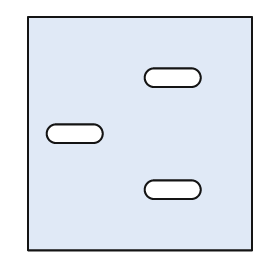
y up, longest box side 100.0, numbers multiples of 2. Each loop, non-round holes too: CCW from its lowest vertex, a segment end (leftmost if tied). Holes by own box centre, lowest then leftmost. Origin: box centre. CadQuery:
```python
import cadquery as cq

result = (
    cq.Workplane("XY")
    .moveTo(-48.0, -50.0)
    .lineTo(48.0, -50.0)
    .lineTo(48.0, 50.0)
    .lineTo(-48.0, 50.0)
    .close()
    .moveTo(6.0, -28.0)
    .lineTo(22.0, -28.0)
    .threePointArc((26.0, -24.0), (22.0, -20.0))
    .lineTo(6.0, -20.0)
    .threePointArc((2.0, -24.0), (6.0, -28.0))
    .close()
    .moveTo(-36.0, -4.0)
    .lineTo(-20.0, -4.0)
    .threePointArc((-16.0, 0.0), (-20.0, 4.0))
    .lineTo(-36.0, 4.0)
    .threePointArc((-40.0, 0.0), (-36.0, -4.0))
    .close()
    .moveTo(6.0, 20.0)
    .lineTo(22.0, 20.0)
    .threePointArc((26.0, 24.0), (22.0, 28.0))
    .lineTo(6.0, 28.0)
    .threePointArc((2.0, 24.0), (6.0, 20.0))
    .close()
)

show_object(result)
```